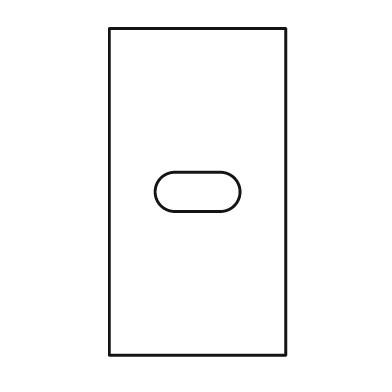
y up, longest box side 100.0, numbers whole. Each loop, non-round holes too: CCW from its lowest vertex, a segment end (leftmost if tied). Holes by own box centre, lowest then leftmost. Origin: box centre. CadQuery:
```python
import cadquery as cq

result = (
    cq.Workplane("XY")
    .moveTo(-27.0, -50.0)
    .lineTo(27.0, -50.0)
    .lineTo(27.0, 50.0)
    .lineTo(-27.0, 50.0)
    .close()
    .moveTo(-7.0, -6.0)
    .lineTo(7.0, -6.0)
    .threePointArc((13.0, 0.0), (7.0, 6.0))
    .lineTo(-7.0, 6.0)
    .threePointArc((-13.0, 0.0), (-7.0, -6.0))
    .close()
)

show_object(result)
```